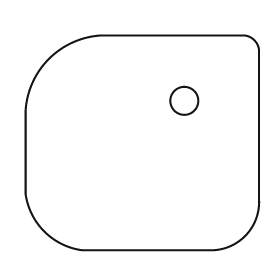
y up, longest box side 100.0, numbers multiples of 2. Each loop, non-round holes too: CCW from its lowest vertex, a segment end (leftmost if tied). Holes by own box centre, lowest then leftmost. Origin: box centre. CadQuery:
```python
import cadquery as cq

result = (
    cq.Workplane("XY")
    .moveTo(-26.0, -46.0)
    .lineTo(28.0, -46.0)
    .threePointArc((44.0, -40.0), (50.0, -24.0))
    .lineTo(50.0, 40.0)
    .threePointArc((48.0, 44.0), (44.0, 46.0))
    .lineTo(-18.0, 46.0)
    .threePointArc((-40.0, 36.0), (-50.0, 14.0))
    .lineTo(-50.0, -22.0)
    .threePointArc((-42.0, -38.0), (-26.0, -46.0))
    .close()
    .moveTo(18.0, 18.0)
    .circle(6.0)
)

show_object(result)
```